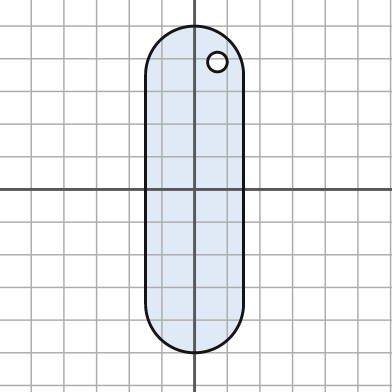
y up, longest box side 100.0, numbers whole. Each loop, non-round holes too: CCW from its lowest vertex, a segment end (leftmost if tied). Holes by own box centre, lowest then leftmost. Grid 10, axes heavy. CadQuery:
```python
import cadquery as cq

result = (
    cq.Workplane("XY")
    .moveTo(-15.0, -35.0)
    .threePointArc((0.0, -50.0), (15.0, -35.0))
    .lineTo(15.0, 35.0)
    .threePointArc((0.0, 50.0), (-15.0, 35.0))
    .close()
    .moveTo(7.0, 39.0)
    .circle(3.0)
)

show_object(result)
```